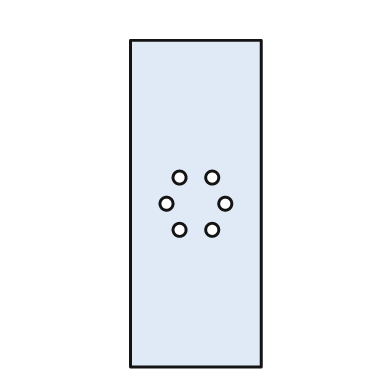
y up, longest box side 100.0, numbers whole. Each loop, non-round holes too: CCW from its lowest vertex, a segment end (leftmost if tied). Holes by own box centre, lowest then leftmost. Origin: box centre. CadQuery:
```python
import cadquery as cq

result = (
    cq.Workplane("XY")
    .moveTo(-20.0, -50.0)
    .lineTo(20.0, -50.0)
    .lineTo(20.0, 50.0)
    .lineTo(-20.0, 50.0)
    .close()
    .moveTo(-5.0, -8.0)
    .circle(2.0)
    .moveTo(5.0, -8.0)
    .circle(2.0)
    .moveTo(-9.0, 0.0)
    .circle(2.0)
    .moveTo(9.0, 0.0)
    .circle(2.0)
    .moveTo(-5.0, 8.0)
    .circle(2.0)
    .moveTo(5.0, 8.0)
    .circle(2.0)
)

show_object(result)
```